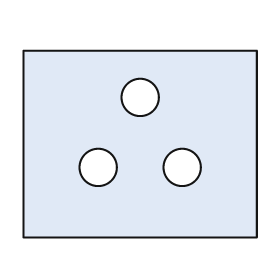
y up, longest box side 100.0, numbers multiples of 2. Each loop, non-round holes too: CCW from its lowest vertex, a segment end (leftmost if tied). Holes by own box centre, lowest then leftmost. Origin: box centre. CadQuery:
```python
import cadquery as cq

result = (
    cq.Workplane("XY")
    .moveTo(-50.0, -40.0)
    .lineTo(50.0, -40.0)
    .lineTo(50.0, 40.0)
    .lineTo(-50.0, 40.0)
    .close()
    .moveTo(-18.0, -10.0)
    .circle(8.0)
    .moveTo(18.0, -10.0)
    .circle(8.0)
    .moveTo(0.0, 20.0)
    .circle(8.0)
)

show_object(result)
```